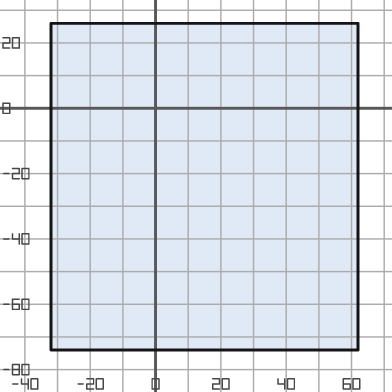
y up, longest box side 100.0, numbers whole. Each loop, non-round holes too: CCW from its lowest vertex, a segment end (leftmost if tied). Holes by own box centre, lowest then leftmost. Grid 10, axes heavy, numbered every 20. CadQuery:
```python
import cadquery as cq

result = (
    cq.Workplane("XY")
    .moveTo(-32.0, -74.0)
    .lineTo(62.0, -74.0)
    .lineTo(62.0, 26.0)
    .lineTo(-32.0, 26.0)
    .close()
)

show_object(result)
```